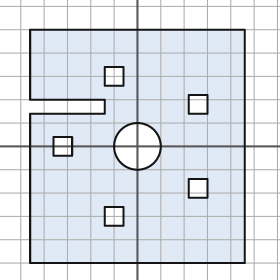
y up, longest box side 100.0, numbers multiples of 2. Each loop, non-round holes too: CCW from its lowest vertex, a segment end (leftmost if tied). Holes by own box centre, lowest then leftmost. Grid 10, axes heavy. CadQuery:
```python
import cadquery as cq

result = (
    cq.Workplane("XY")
    .moveTo(-46.0, -50.0)
    .lineTo(46.0, -50.0)
    .lineTo(46.0, 50.0)
    .lineTo(-46.0, 50.0)
    .lineTo(-46.0, 20.0)
    .lineTo(-14.0, 20.0)
    .lineTo(-14.0, 14.0)
    .lineTo(-46.0, 14.0)
    .close()
    .moveTo(-14.0, -34.0)
    .lineTo(-6.0, -34.0)
    .lineTo(-6.0, -26.0)
    .lineTo(-14.0, -26.0)
    .close()
    .moveTo(22.0, -22.0)
    .lineTo(30.0, -22.0)
    .lineTo(30.0, -14.0)
    .lineTo(22.0, -14.0)
    .close()
    .moveTo(-36.0, -4.0)
    .lineTo(-28.0, -4.0)
    .lineTo(-28.0, 4.0)
    .lineTo(-36.0, 4.0)
    .close()
    .moveTo(0.0, 0.0)
    .circle(10.0)
    .moveTo(22.0, 14.0)
    .lineTo(30.0, 14.0)
    .lineTo(30.0, 22.0)
    .lineTo(22.0, 22.0)
    .close()
    .moveTo(-14.0, 26.0)
    .lineTo(-6.0, 26.0)
    .lineTo(-6.0, 34.0)
    .lineTo(-14.0, 34.0)
    .close()
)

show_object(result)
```